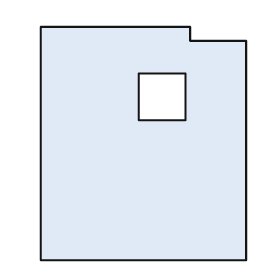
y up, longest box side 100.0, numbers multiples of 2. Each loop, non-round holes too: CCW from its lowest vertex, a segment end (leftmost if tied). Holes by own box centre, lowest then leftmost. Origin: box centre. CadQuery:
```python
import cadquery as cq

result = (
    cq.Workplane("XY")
    .moveTo(-44.0, -50.0)
    .lineTo(44.0, -50.0)
    .lineTo(44.0, 44.0)
    .lineTo(20.0, 44.0)
    .lineTo(20.0, 50.0)
    .lineTo(-44.0, 50.0)
    .close()
    .moveTo(-2.0, 10.0)
    .lineTo(18.0, 10.0)
    .lineTo(18.0, 30.0)
    .lineTo(-2.0, 30.0)
    .close()
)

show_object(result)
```